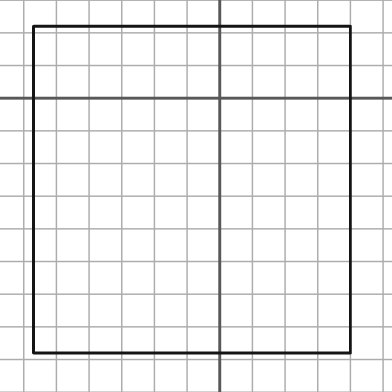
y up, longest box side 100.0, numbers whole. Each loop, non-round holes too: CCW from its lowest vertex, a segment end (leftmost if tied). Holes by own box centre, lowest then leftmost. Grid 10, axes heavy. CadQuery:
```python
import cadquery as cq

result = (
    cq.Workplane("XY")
    .moveTo(-57.0, -78.0)
    .lineTo(40.0, -78.0)
    .lineTo(40.0, 22.0)
    .lineTo(-57.0, 22.0)
    .close()
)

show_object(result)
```